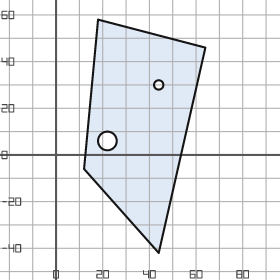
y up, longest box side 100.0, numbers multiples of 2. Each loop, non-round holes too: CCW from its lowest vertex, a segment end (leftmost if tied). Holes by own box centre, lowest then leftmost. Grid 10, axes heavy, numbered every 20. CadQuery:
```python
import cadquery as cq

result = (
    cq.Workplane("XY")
    .moveTo(44.0, -42.0)
    .lineTo(64.0, 46.0)
    .lineTo(18.0, 58.0)
    .lineTo(12.0, -6.0)
    .close()
    .moveTo(22.0, 6.0)
    .circle(4.0)
    .moveTo(44.0, 30.0)
    .circle(2.0)
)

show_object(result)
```